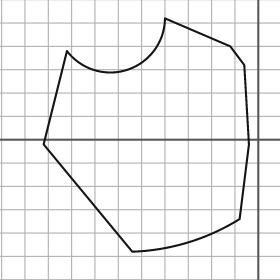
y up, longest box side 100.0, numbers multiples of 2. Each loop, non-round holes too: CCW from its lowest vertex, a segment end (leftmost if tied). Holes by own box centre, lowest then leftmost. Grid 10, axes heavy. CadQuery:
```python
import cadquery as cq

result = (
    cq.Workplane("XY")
    .moveTo(-54.0, -48.0)
    .threePointArc((-30.0, -44.0), (-8.0, -34.0))
    .lineTo(-4.0, -2.0)
    .lineTo(-6.0, 32.0)
    .lineTo(-12.0, 40.0)
    .lineTo(-40.0, 52.0)
    .threePointArc((-56.0, 30.0), (-82.0, 38.0))
    .lineTo(-92.0, -2.0)
    .close()
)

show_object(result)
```